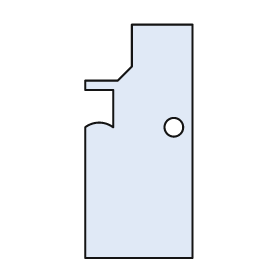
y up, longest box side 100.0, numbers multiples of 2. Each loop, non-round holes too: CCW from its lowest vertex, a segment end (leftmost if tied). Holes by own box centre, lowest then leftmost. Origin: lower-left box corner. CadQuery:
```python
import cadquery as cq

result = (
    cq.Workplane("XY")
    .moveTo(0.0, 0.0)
    .lineTo(46.0, 0.0)
    .lineTo(46.0, 100.0)
    .lineTo(20.0, 100.0)
    .lineTo(20.0, 82.0)
    .lineTo(14.0, 76.0)
    .lineTo(0.0, 76.0)
    .lineTo(0.0, 72.0)
    .lineTo(12.0, 72.0)
    .lineTo(12.0, 56.0)
    .threePointArc((6.0, 58.0), (0.0, 56.0))
    .close()
    .moveTo(38.0, 56.0)
    .circle(4.0)
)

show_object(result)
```